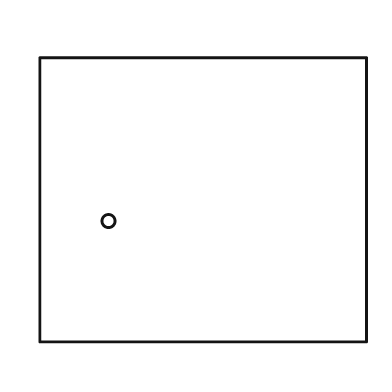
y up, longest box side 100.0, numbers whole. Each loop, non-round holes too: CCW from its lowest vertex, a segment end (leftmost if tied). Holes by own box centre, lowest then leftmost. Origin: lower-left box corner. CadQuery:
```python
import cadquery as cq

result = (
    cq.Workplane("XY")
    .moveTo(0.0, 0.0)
    .lineTo(100.0, 0.0)
    .lineTo(100.0, 87.0)
    .lineTo(0.0, 87.0)
    .close()
    .moveTo(21.0, 37.0)
    .circle(2.0)
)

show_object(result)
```